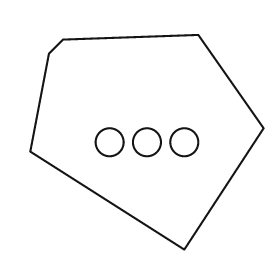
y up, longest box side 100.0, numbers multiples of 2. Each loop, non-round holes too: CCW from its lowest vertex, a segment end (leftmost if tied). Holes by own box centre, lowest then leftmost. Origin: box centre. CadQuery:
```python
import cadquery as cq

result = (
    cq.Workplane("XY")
    .moveTo(16.0, -46.0)
    .lineTo(50.0, 6.0)
    .lineTo(22.0, 46.0)
    .lineTo(-36.0, 44.0)
    .lineTo(-42.0, 38.0)
    .lineTo(-50.0, -4.0)
    .close()
    .moveTo(-16.0, 0.0)
    .circle(6.0)
    .moveTo(0.0, 0.0)
    .circle(6.0)
    .moveTo(16.0, 0.0)
    .circle(6.0)
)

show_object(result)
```